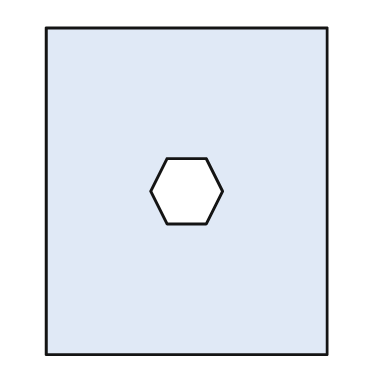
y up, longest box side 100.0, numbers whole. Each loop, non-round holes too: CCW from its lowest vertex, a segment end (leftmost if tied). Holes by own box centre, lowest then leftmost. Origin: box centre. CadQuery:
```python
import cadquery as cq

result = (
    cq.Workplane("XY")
    .moveTo(-43.0, -50.0)
    .lineTo(43.0, -50.0)
    .lineTo(43.0, 50.0)
    .lineTo(-43.0, 50.0)
    .close()
    .moveTo(-6.0, -10.0)
    .lineTo(6.0, -10.0)
    .lineTo(11.0, 0.0)
    .lineTo(6.0, 10.0)
    .lineTo(-6.0, 10.0)
    .lineTo(-11.0, 0.0)
    .close()
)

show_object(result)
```